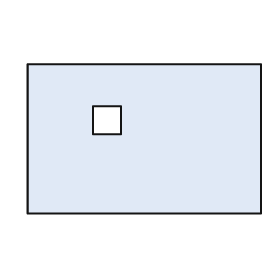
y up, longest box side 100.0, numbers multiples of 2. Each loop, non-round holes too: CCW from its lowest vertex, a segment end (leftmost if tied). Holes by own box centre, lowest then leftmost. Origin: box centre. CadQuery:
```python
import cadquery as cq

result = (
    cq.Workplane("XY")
    .moveTo(-50.0, -32.0)
    .lineTo(50.0, -32.0)
    .lineTo(50.0, 32.0)
    .lineTo(-50.0, 32.0)
    .close()
    .moveTo(-22.0, 2.0)
    .lineTo(-10.0, 2.0)
    .lineTo(-10.0, 14.0)
    .lineTo(-22.0, 14.0)
    .close()
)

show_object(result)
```